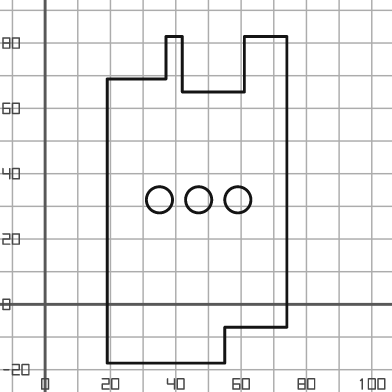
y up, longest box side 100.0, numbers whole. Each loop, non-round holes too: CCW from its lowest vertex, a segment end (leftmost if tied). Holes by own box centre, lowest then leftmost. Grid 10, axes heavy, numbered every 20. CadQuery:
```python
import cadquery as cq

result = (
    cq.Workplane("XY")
    .moveTo(19.0, -18.0)
    .lineTo(55.0, -18.0)
    .lineTo(55.0, -7.0)
    .lineTo(74.0, -7.0)
    .lineTo(74.0, 82.0)
    .lineTo(61.0, 82.0)
    .lineTo(61.0, 65.0)
    .lineTo(42.0, 65.0)
    .lineTo(42.0, 82.0)
    .lineTo(37.0, 82.0)
    .lineTo(37.0, 69.0)
    .lineTo(19.0, 69.0)
    .close()
    .moveTo(35.0, 32.0)
    .circle(4.0)
    .moveTo(47.0, 32.0)
    .circle(4.0)
    .moveTo(59.0, 32.0)
    .circle(4.0)
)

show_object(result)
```